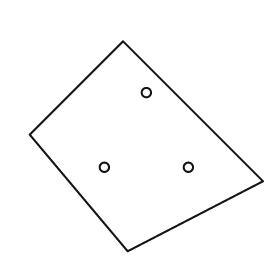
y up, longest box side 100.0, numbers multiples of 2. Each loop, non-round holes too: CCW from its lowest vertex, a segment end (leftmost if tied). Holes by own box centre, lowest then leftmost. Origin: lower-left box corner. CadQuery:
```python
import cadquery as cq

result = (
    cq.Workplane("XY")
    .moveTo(42.0, 0.0)
    .lineTo(100.0, 30.0)
    .lineTo(40.0, 90.0)
    .lineTo(0.0, 50.0)
    .close()
    .moveTo(32.0, 36.0)
    .circle(2.0)
    .moveTo(68.0, 36.0)
    .circle(2.0)
    .moveTo(50.0, 68.0)
    .circle(2.0)
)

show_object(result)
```